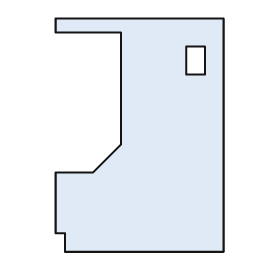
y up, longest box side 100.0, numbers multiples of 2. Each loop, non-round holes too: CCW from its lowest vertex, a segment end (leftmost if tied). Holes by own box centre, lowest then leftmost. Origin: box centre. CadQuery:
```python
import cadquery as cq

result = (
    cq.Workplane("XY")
    .moveTo(-32.0, -50.0)
    .lineTo(36.0, -50.0)
    .lineTo(36.0, 50.0)
    .lineTo(-36.0, 50.0)
    .lineTo(-36.0, 44.0)
    .lineTo(-8.0, 44.0)
    .lineTo(-8.0, -4.0)
    .lineTo(-20.0, -16.0)
    .lineTo(-36.0, -16.0)
    .lineTo(-36.0, -42.0)
    .lineTo(-32.0, -42.0)
    .close()
    .moveTo(20.0, 26.0)
    .lineTo(28.0, 26.0)
    .lineTo(28.0, 38.0)
    .lineTo(20.0, 38.0)
    .close()
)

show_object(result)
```